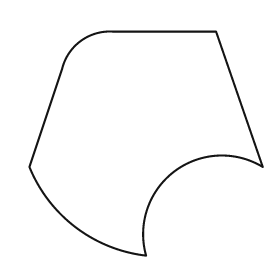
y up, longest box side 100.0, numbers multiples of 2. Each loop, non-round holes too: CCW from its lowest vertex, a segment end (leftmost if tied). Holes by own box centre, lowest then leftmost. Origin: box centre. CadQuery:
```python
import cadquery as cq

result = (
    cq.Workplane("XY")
    .moveTo(0.0, -48.0)
    .threePointArc((12.0, -12.0), (50.0, -10.0))
    .lineTo(30.0, 48.0)
    .lineTo(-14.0, 48.0)
    .threePointArc((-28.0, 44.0), (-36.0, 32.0))
    .lineTo(-50.0, -10.0)
    .threePointArc((-30.0, -36.0), (0.0, -48.0))
    .close()
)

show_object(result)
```